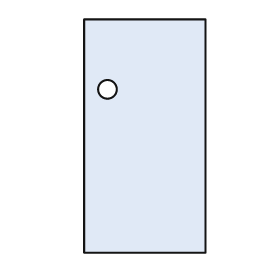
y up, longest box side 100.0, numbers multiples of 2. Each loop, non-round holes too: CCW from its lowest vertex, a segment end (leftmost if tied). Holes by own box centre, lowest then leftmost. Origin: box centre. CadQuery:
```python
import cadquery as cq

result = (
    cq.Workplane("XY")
    .moveTo(-26.0, -50.0)
    .lineTo(26.0, -50.0)
    .lineTo(26.0, 50.0)
    .lineTo(-26.0, 50.0)
    .close()
    .moveTo(-16.0, 20.0)
    .circle(4.0)
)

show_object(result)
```